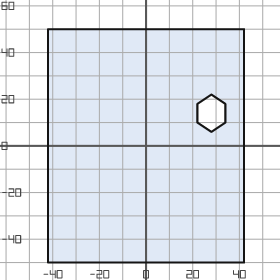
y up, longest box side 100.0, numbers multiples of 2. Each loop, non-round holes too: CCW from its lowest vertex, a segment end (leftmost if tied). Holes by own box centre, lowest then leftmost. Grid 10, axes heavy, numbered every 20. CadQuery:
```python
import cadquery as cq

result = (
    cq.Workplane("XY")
    .moveTo(-42.0, -50.0)
    .lineTo(42.0, -50.0)
    .lineTo(42.0, 50.0)
    .lineTo(-42.0, 50.0)
    .close()
    .moveTo(28.0, 6.0)
    .lineTo(34.0, 10.0)
    .lineTo(34.0, 18.0)
    .lineTo(28.0, 22.0)
    .lineTo(22.0, 18.0)
    .lineTo(22.0, 10.0)
    .close()
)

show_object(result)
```